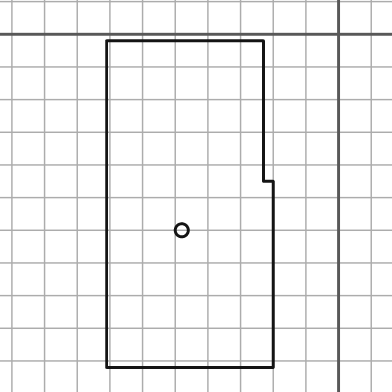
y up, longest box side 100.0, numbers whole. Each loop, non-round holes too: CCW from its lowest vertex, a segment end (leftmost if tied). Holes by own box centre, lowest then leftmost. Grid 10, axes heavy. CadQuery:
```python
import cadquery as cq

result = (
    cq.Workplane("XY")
    .moveTo(-71.0, -102.0)
    .lineTo(-20.0, -102.0)
    .lineTo(-20.0, -45.0)
    .lineTo(-23.0, -45.0)
    .lineTo(-23.0, -2.0)
    .lineTo(-71.0, -2.0)
    .close()
    .moveTo(-48.0, -60.0)
    .circle(2.0)
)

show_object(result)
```